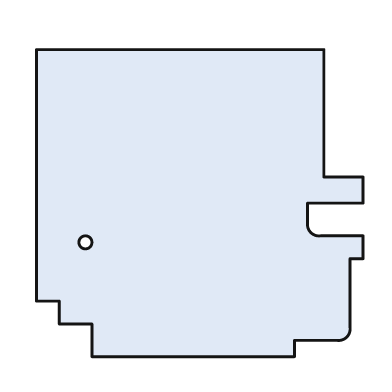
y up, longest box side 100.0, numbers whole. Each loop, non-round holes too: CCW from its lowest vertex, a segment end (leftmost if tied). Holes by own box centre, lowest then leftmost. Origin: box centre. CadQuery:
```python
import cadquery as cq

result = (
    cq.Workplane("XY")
    .moveTo(-33.0, -47.0)
    .lineTo(29.0, -47.0)
    .lineTo(29.0, -42.0)
    .lineTo(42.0, -42.0)
    .threePointArc((45.0, -41.0), (46.0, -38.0))
    .lineTo(46.0, -17.0)
    .lineTo(50.0, -17.0)
    .lineTo(50.0, -10.0)
    .lineTo(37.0, -10.0)
    .threePointArc((34.0, -9.0), (33.0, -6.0))
    .lineTo(33.0, 0.0)
    .lineTo(50.0, 0.0)
    .lineTo(50.0, 8.0)
    .lineTo(38.0, 8.0)
    .lineTo(38.0, 47.0)
    .lineTo(-50.0, 47.0)
    .lineTo(-50.0, -30.0)
    .lineTo(-43.0, -30.0)
    .lineTo(-43.0, -37.0)
    .lineTo(-33.0, -37.0)
    .close()
    .moveTo(-35.0, -12.0)
    .circle(2.0)
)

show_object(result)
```